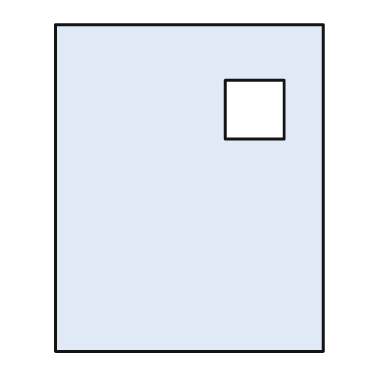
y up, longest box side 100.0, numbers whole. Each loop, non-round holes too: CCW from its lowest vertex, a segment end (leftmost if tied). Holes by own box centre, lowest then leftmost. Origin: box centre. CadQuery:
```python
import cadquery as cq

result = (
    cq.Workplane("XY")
    .moveTo(-41.0, -50.0)
    .lineTo(41.0, -50.0)
    .lineTo(41.0, 50.0)
    .lineTo(-41.0, 50.0)
    .close()
    .moveTo(11.0, 15.0)
    .lineTo(29.0, 15.0)
    .lineTo(29.0, 33.0)
    .lineTo(11.0, 33.0)
    .close()
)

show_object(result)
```